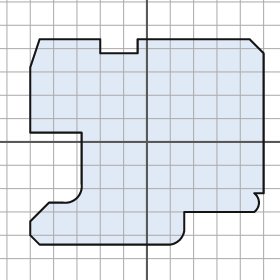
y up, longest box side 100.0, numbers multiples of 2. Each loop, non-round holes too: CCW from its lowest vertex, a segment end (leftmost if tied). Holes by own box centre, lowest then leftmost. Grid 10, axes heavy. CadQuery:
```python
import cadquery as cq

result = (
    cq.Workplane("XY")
    .moveTo(-46.0, -44.0)
    .lineTo(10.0, -44.0)
    .threePointArc((14.0, -42.0), (16.0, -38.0))
    .lineTo(16.0, -30.0)
    .lineTo(46.0, -30.0)
    .threePointArc((48.0, -26.0), (46.0, -22.0))
    .lineTo(50.0, -22.0)
    .lineTo(50.0, 38.0)
    .lineTo(44.0, 44.0)
    .lineTo(-4.0, 44.0)
    .lineTo(-4.0, 38.0)
    .lineTo(-20.0, 38.0)
    .lineTo(-20.0, 44.0)
    .lineTo(-46.0, 44.0)
    .lineTo(-50.0, 32.0)
    .lineTo(-50.0, 4.0)
    .lineTo(-28.0, 4.0)
    .lineTo(-28.0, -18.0)
    .threePointArc((-30.0, -24.0), (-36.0, -26.0))
    .lineTo(-42.0, -26.0)
    .lineTo(-50.0, -34.0)
    .lineTo(-50.0, -40.0)
    .close()
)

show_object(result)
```